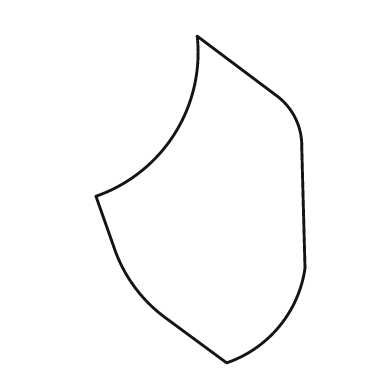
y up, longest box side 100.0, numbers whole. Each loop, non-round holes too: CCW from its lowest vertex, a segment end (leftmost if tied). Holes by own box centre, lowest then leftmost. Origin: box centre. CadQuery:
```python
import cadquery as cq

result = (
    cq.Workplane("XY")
    .moveTo(8.0, -50.0)
    .threePointArc((24.0, -39.0), (32.0, -21.0))
    .lineTo(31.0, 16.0)
    .threePointArc((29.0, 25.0), (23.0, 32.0))
    .lineTo(-1.0, 50.0)
    .threePointArc((-8.0, 20.0), (-32.0, 1.0))
    .lineTo(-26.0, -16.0)
    .threePointArc((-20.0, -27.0), (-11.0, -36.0))
    .close()
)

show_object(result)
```